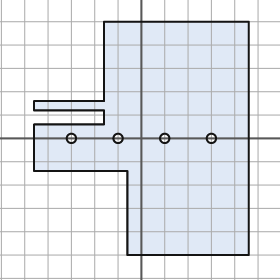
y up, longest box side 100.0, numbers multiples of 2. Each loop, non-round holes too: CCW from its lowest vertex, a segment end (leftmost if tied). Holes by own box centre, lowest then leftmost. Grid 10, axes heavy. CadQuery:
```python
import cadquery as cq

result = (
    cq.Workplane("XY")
    .moveTo(-6.0, -50.0)
    .lineTo(46.0, -50.0)
    .lineTo(46.0, 50.0)
    .lineTo(-16.0, 50.0)
    .lineTo(-16.0, 16.0)
    .lineTo(-46.0, 16.0)
    .lineTo(-46.0, 12.0)
    .lineTo(-16.0, 12.0)
    .lineTo(-16.0, 6.0)
    .lineTo(-46.0, 6.0)
    .lineTo(-46.0, -14.0)
    .lineTo(-6.0, -14.0)
    .close()
    .moveTo(-30.0, 0.0)
    .circle(2.0)
    .moveTo(-10.0, 0.0)
    .circle(2.0)
    .moveTo(10.0, 0.0)
    .circle(2.0)
    .moveTo(30.0, 0.0)
    .circle(2.0)
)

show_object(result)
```